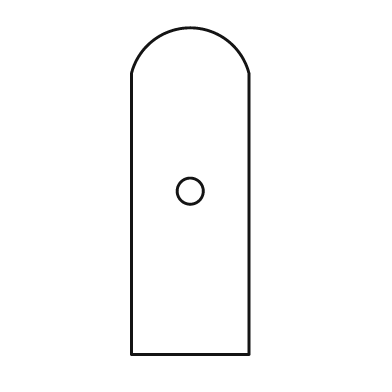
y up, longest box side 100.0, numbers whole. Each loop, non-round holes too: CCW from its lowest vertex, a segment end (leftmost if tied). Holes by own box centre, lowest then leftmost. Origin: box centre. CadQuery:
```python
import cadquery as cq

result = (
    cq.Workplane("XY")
    .moveTo(-18.0, -50.0)
    .lineTo(18.0, -50.0)
    .lineTo(18.0, 36.0)
    .threePointArc((0.0, 50.0), (-18.0, 36.0))
    .close()
    .moveTo(0.0, 0.0)
    .circle(4.0)
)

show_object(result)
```